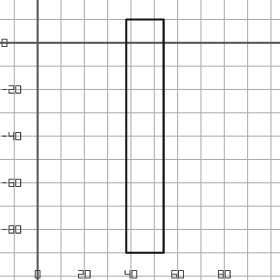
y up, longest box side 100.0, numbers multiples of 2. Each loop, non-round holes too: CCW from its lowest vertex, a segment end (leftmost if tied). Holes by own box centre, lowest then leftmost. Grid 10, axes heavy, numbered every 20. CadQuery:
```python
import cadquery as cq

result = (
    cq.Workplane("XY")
    .moveTo(38.0, -90.0)
    .lineTo(54.0, -90.0)
    .lineTo(54.0, 10.0)
    .lineTo(38.0, 10.0)
    .close()
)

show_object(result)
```